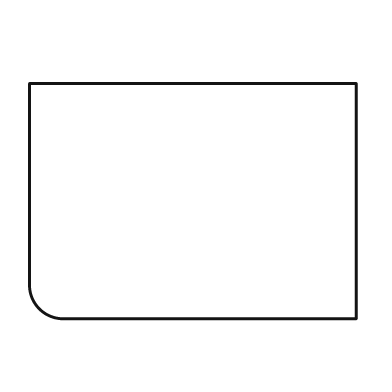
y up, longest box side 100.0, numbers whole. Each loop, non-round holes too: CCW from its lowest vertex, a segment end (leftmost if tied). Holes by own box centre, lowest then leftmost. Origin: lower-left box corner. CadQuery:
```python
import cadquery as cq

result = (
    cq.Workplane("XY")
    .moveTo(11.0, 0.0)
    .lineTo(100.0, 0.0)
    .lineTo(100.0, 72.0)
    .lineTo(0.0, 72.0)
    .lineTo(0.0, 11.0)
    .threePointArc((3.0, 3.0), (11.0, 0.0))
    .close()
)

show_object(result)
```